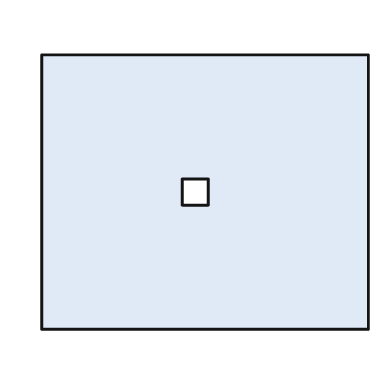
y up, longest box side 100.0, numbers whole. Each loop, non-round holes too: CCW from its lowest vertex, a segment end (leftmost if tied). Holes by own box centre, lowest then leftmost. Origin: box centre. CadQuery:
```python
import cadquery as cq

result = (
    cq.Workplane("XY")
    .moveTo(-50.0, -42.0)
    .lineTo(50.0, -42.0)
    .lineTo(50.0, 42.0)
    .lineTo(-50.0, 42.0)
    .close()
    .moveTo(-7.0, -4.0)
    .lineTo(1.0, -4.0)
    .lineTo(1.0, 4.0)
    .lineTo(-7.0, 4.0)
    .close()
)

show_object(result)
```